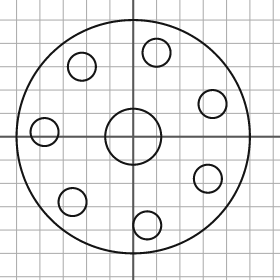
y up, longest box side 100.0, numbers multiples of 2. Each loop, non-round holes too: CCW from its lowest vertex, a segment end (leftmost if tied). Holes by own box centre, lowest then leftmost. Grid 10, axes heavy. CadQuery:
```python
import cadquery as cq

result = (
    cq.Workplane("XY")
    .moveTo(0.0, 0.0)
    .circle(50.0)
    .moveTo(6.0, -38.0)
    .circle(6.0)
    .moveTo(-26.0, -28.0)
    .circle(6.0)
    .moveTo(32.0, -18.0)
    .circle(6.0)
    .moveTo(0.0, 0.0)
    .circle(12.0)
    .moveTo(-38.0, 2.0)
    .circle(6.0)
    .moveTo(34.0, 14.0)
    .circle(6.0)
    .moveTo(-22.0, 30.0)
    .circle(6.0)
    .moveTo(10.0, 36.0)
    .circle(6.0)
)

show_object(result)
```